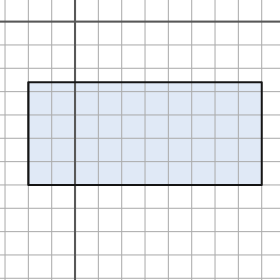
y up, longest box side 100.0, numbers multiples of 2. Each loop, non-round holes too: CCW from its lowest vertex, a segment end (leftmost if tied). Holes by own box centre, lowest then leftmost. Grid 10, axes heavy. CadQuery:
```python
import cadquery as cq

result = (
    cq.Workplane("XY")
    .moveTo(-20.0, -70.0)
    .lineTo(80.0, -70.0)
    .lineTo(80.0, -26.0)
    .lineTo(-20.0, -26.0)
    .close()
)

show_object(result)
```